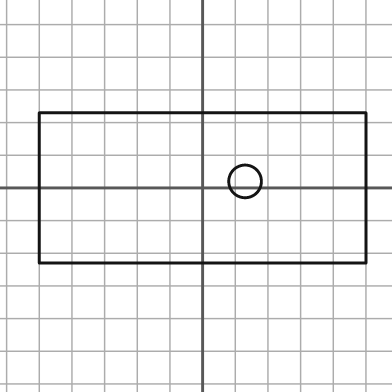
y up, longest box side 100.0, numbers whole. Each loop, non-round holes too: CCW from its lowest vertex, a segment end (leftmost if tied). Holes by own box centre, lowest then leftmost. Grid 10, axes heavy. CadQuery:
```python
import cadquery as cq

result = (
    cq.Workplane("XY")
    .moveTo(-50.0, -23.0)
    .lineTo(50.0, -23.0)
    .lineTo(50.0, 23.0)
    .lineTo(-50.0, 23.0)
    .close()
    .moveTo(13.0, 2.0)
    .circle(5.0)
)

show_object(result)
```